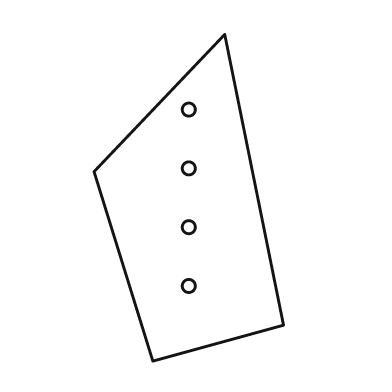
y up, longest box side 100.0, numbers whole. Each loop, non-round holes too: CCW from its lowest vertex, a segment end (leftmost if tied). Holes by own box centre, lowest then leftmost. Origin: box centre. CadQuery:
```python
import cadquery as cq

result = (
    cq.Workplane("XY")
    .moveTo(-11.0, -50.0)
    .lineTo(29.0, -39.0)
    .lineTo(11.0, 50.0)
    .lineTo(-29.0, 8.0)
    .close()
    .moveTo(0.0, -27.0)
    .circle(2.0)
    .moveTo(0.0, -9.0)
    .circle(2.0)
    .moveTo(0.0, 9.0)
    .circle(2.0)
    .moveTo(0.0, 27.0)
    .circle(2.0)
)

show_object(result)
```